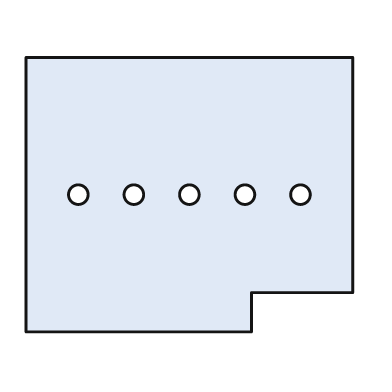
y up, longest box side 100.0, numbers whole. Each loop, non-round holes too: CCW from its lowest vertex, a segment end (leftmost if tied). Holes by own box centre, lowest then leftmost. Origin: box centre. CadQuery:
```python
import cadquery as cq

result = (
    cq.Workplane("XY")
    .moveTo(-50.0, -42.0)
    .lineTo(19.0, -42.0)
    .lineTo(19.0, -30.0)
    .lineTo(50.0, -30.0)
    .lineTo(50.0, 42.0)
    .lineTo(-50.0, 42.0)
    .close()
    .moveTo(-34.0, 0.0)
    .circle(3.0)
    .moveTo(-17.0, 0.0)
    .circle(3.0)
    .moveTo(0.0, 0.0)
    .circle(3.0)
    .moveTo(17.0, 0.0)
    .circle(3.0)
    .moveTo(34.0, 0.0)
    .circle(3.0)
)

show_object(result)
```